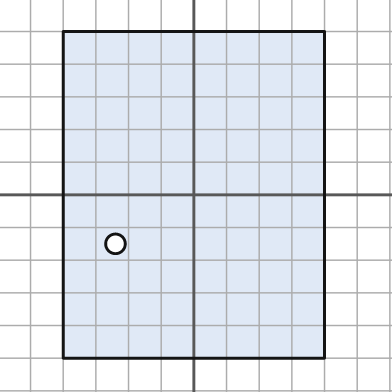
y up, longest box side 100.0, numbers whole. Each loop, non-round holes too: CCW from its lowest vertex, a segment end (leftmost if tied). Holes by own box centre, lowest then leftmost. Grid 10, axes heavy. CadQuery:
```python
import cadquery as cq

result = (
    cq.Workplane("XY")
    .moveTo(-40.0, -50.0)
    .lineTo(40.0, -50.0)
    .lineTo(40.0, 50.0)
    .lineTo(-40.0, 50.0)
    .close()
    .moveTo(-24.0, -15.0)
    .circle(3.0)
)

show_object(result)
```